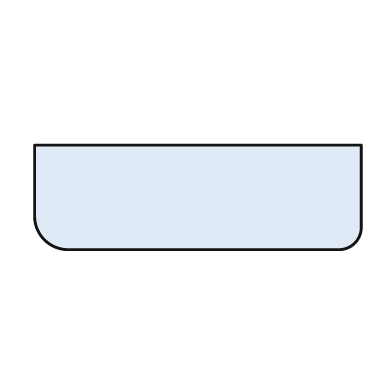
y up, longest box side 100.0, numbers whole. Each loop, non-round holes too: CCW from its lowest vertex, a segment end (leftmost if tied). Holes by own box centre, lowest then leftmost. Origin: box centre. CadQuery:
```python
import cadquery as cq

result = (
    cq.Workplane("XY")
    .moveTo(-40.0, -16.0)
    .lineTo(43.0, -16.0)
    .threePointArc((48.0, -14.0), (50.0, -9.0))
    .lineTo(50.0, 16.0)
    .lineTo(-50.0, 16.0)
    .lineTo(-50.0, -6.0)
    .threePointArc((-47.0, -13.0), (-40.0, -16.0))
    .close()
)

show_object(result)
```